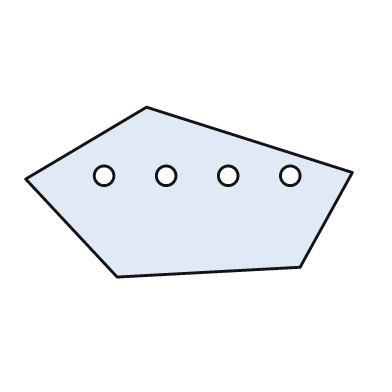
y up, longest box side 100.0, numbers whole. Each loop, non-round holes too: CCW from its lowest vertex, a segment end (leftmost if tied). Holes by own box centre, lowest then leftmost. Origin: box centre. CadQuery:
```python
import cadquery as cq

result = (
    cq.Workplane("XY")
    .moveTo(-22.0, -26.0)
    .lineTo(34.0, -23.0)
    .lineTo(50.0, 6.0)
    .lineTo(-13.0, 26.0)
    .lineTo(-50.0, 4.0)
    .close()
    .moveTo(-26.0, 5.0)
    .circle(3.0)
    .moveTo(-7.0, 5.0)
    .circle(3.0)
    .moveTo(12.0, 5.0)
    .circle(3.0)
    .moveTo(31.0, 5.0)
    .circle(3.0)
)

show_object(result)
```